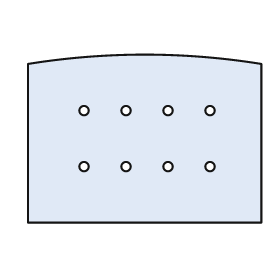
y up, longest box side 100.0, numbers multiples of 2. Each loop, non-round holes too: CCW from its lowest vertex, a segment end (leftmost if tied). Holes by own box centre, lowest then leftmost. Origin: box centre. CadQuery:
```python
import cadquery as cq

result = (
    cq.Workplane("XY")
    .moveTo(-50.0, -36.0)
    .lineTo(50.0, -36.0)
    .lineTo(50.0, 32.0)
    .threePointArc((0.0, 36.0), (-50.0, 32.0))
    .close()
    .moveTo(-26.0, -12.0)
    .circle(2.0)
    .moveTo(-8.0, -12.0)
    .circle(2.0)
    .moveTo(10.0, -12.0)
    .circle(2.0)
    .moveTo(28.0, -12.0)
    .circle(2.0)
    .moveTo(-26.0, 12.0)
    .circle(2.0)
    .moveTo(-8.0, 12.0)
    .circle(2.0)
    .moveTo(10.0, 12.0)
    .circle(2.0)
    .moveTo(28.0, 12.0)
    .circle(2.0)
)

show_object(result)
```